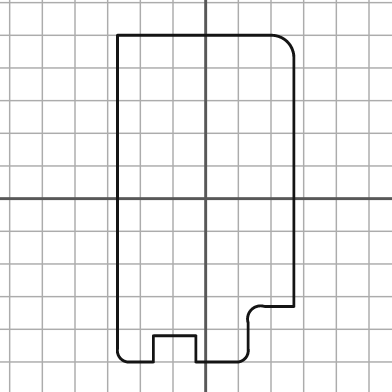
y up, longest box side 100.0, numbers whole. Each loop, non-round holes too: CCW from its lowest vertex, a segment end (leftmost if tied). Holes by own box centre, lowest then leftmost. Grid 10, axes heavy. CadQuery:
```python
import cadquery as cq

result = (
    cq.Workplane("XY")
    .moveTo(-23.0, -50.0)
    .lineTo(-16.0, -50.0)
    .lineTo(-16.0, -42.0)
    .lineTo(-3.0, -42.0)
    .lineTo(-3.0, -50.0)
    .lineTo(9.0, -50.0)
    .threePointArc((12.0, -49.0), (13.0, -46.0))
    .lineTo(13.0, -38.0)
    .threePointArc((14.0, -34.0), (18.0, -33.0))
    .lineTo(27.0, -33.0)
    .lineTo(27.0, 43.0)
    .threePointArc((25.0, 48.0), (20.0, 50.0))
    .lineTo(-27.0, 50.0)
    .lineTo(-27.0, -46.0)
    .threePointArc((-26.0, -49.0), (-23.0, -50.0))
    .close()
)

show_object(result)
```